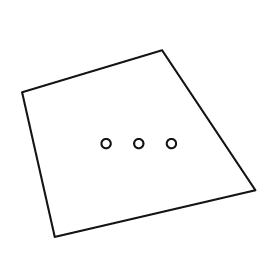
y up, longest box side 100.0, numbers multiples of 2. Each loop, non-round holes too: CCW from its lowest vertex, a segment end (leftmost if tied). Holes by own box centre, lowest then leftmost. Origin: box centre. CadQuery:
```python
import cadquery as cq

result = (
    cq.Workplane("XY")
    .moveTo(-36.0, -40.0)
    .lineTo(50.0, -20.0)
    .lineTo(10.0, 40.0)
    .lineTo(-50.0, 22.0)
    .close()
    .moveTo(-14.0, 0.0)
    .circle(2.0)
    .moveTo(0.0, 0.0)
    .circle(2.0)
    .moveTo(14.0, 0.0)
    .circle(2.0)
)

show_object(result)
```